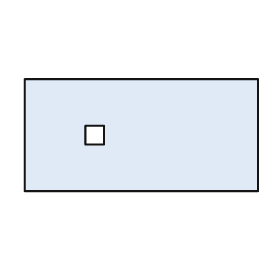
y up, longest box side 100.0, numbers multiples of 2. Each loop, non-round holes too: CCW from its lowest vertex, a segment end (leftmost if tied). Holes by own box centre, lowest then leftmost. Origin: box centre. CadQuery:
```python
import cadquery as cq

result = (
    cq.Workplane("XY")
    .moveTo(-50.0, -24.0)
    .lineTo(50.0, -24.0)
    .lineTo(50.0, 24.0)
    .lineTo(-50.0, 24.0)
    .close()
    .moveTo(-24.0, -4.0)
    .lineTo(-16.0, -4.0)
    .lineTo(-16.0, 4.0)
    .lineTo(-24.0, 4.0)
    .close()
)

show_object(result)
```